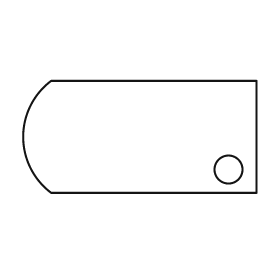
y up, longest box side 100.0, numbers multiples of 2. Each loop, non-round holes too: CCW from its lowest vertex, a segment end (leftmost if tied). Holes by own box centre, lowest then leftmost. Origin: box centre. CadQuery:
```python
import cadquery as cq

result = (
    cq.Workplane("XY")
    .moveTo(-38.0, -24.0)
    .lineTo(50.0, -24.0)
    .lineTo(50.0, 24.0)
    .lineTo(-38.0, 24.0)
    .threePointArc((-50.0, 0.0), (-38.0, -24.0))
    .close()
    .moveTo(38.0, -14.0)
    .circle(6.0)
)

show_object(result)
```